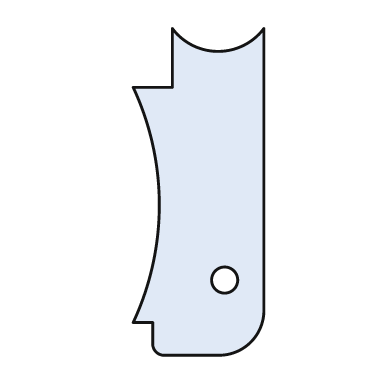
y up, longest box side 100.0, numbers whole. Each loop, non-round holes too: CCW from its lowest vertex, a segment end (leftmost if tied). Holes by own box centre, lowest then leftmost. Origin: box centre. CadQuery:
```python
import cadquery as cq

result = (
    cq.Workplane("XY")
    .moveTo(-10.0, -50.0)
    .lineTo(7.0, -50.0)
    .threePointArc((16.0, -46.0), (20.0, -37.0))
    .lineTo(20.0, 50.0)
    .threePointArc((6.0, 43.0), (-8.0, 50.0))
    .lineTo(-8.0, 32.0)
    .lineTo(-20.0, 32.0)
    .threePointArc((-12.0, -4.0), (-20.0, -40.0))
    .lineTo(-14.0, -40.0)
    .lineTo(-14.0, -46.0)
    .threePointArc((-13.0, -49.0), (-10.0, -50.0))
    .close()
    .moveTo(8.0, -27.0)
    .circle(4.0)
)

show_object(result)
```